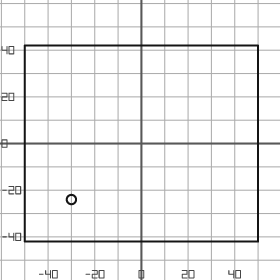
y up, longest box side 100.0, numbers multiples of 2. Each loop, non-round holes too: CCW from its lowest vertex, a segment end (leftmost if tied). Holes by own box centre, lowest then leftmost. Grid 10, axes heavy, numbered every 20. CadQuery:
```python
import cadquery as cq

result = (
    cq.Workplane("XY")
    .moveTo(-50.0, -42.0)
    .lineTo(50.0, -42.0)
    .lineTo(50.0, 42.0)
    .lineTo(-50.0, 42.0)
    .close()
    .moveTo(-30.0, -24.0)
    .circle(2.0)
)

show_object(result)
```